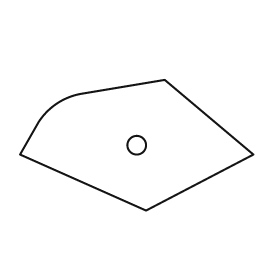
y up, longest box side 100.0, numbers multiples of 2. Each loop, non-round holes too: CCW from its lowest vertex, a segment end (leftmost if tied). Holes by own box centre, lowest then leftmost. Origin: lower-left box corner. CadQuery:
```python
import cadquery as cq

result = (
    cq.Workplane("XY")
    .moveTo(54.0, 0.0)
    .lineTo(100.0, 24.0)
    .lineTo(62.0, 56.0)
    .lineTo(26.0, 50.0)
    .threePointArc((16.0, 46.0), (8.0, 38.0))
    .lineTo(0.0, 24.0)
    .close()
    .moveTo(50.0, 28.0)
    .circle(4.0)
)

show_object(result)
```